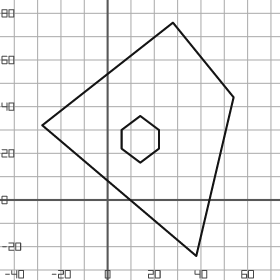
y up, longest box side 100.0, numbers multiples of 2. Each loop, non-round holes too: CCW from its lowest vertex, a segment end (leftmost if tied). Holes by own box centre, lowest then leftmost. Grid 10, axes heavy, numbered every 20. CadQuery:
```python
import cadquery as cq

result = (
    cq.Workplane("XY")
    .moveTo(38.0, -24.0)
    .lineTo(54.0, 44.0)
    .lineTo(28.0, 76.0)
    .lineTo(-28.0, 32.0)
    .close()
    .moveTo(14.0, 16.0)
    .lineTo(22.0, 22.0)
    .lineTo(22.0, 30.0)
    .lineTo(14.0, 36.0)
    .lineTo(6.0, 30.0)
    .lineTo(6.0, 22.0)
    .close()
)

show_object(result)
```